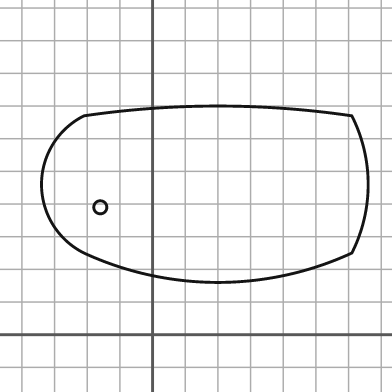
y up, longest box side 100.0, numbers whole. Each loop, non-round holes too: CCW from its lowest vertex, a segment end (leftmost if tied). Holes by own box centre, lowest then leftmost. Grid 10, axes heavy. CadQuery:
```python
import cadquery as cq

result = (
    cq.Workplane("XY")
    .moveTo(-21.0, 25.0)
    .threePointArc((20.0, 16.0), (61.0, 25.0))
    .threePointArc((66.0, 46.0), (61.0, 67.0))
    .threePointArc((20.0, 70.0), (-21.0, 67.0))
    .threePointArc((-34.0, 46.0), (-21.0, 25.0))
    .close()
    .moveTo(-16.0, 39.0)
    .circle(2.0)
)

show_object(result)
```